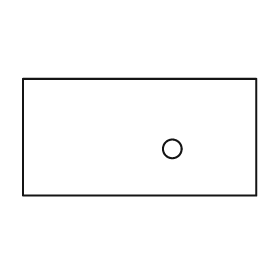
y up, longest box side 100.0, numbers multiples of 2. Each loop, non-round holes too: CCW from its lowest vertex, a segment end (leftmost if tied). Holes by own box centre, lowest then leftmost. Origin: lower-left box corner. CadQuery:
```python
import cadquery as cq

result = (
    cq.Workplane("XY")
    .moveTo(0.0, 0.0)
    .lineTo(100.0, 0.0)
    .lineTo(100.0, 50.0)
    .lineTo(0.0, 50.0)
    .close()
    .moveTo(64.0, 20.0)
    .circle(4.0)
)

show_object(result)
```